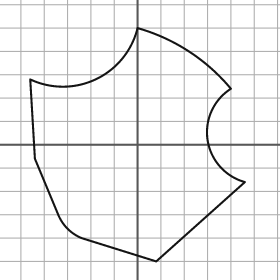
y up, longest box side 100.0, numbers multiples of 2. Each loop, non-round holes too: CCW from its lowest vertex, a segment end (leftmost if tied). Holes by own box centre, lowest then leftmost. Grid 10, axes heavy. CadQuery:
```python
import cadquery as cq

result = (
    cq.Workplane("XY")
    .moveTo(8.0, -50.0)
    .lineTo(46.0, -16.0)
    .threePointArc((30.0, 2.0), (40.0, 24.0))
    .threePointArc((22.0, 40.0), (0.0, 50.0))
    .threePointArc((-18.0, 28.0), (-46.0, 28.0))
    .lineTo(-44.0, -6.0)
    .lineTo(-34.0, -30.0)
    .threePointArc((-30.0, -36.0), (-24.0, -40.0))
    .close()
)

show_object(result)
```